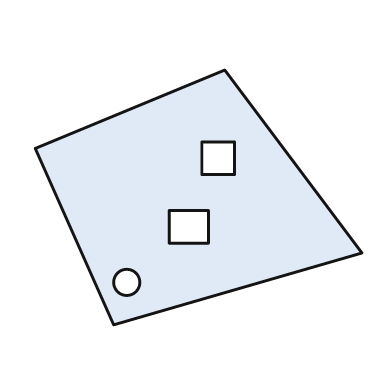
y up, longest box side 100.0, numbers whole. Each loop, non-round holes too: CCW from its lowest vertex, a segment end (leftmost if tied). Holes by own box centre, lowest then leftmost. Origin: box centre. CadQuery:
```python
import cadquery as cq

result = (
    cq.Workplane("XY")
    .moveTo(-26.0, -39.0)
    .lineTo(50.0, -17.0)
    .lineTo(8.0, 39.0)
    .lineTo(-50.0, 15.0)
    .close()
    .moveTo(-22.0, -26.0)
    .circle(4.0)
    .moveTo(-9.0, -14.0)
    .lineTo(3.0, -14.0)
    .lineTo(3.0, -4.0)
    .lineTo(-9.0, -4.0)
    .close()
    .moveTo(1.0, 7.0)
    .lineTo(11.0, 7.0)
    .lineTo(11.0, 17.0)
    .lineTo(1.0, 17.0)
    .close()
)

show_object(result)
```